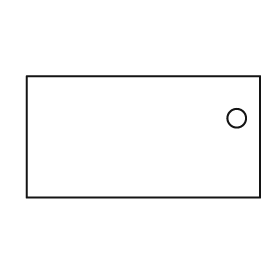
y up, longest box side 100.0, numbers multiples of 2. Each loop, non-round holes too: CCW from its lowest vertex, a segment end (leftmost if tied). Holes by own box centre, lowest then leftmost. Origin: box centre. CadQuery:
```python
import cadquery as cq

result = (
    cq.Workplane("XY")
    .moveTo(-50.0, -26.0)
    .lineTo(50.0, -26.0)
    .lineTo(50.0, 26.0)
    .lineTo(-50.0, 26.0)
    .close()
    .moveTo(40.0, 8.0)
    .circle(4.0)
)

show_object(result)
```